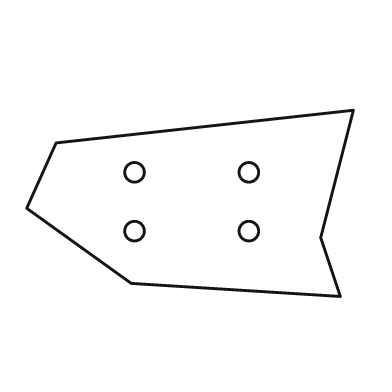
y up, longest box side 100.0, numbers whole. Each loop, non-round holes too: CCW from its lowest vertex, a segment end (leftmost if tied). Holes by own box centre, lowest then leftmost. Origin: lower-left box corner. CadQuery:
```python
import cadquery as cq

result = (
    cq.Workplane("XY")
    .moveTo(96.0, 0.0)
    .lineTo(90.0, 18.0)
    .lineTo(100.0, 57.0)
    .lineTo(9.0, 47.0)
    .lineTo(0.0, 27.0)
    .lineTo(32.0, 4.0)
    .close()
    .moveTo(33.0, 20.0)
    .circle(3.0)
    .moveTo(68.0, 20.0)
    .circle(3.0)
    .moveTo(33.0, 38.0)
    .circle(3.0)
    .moveTo(68.0, 38.0)
    .circle(3.0)
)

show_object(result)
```